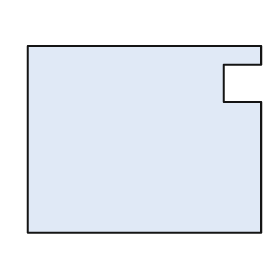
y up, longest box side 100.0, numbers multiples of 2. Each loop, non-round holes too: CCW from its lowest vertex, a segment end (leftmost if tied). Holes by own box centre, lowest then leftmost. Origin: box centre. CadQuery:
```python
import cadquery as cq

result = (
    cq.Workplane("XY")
    .moveTo(-50.0, -40.0)
    .lineTo(50.0, -40.0)
    .lineTo(50.0, 16.0)
    .lineTo(34.0, 16.0)
    .lineTo(34.0, 32.0)
    .lineTo(50.0, 32.0)
    .lineTo(50.0, 40.0)
    .lineTo(-50.0, 40.0)
    .close()
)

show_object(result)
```